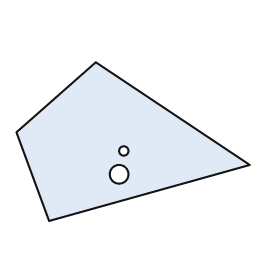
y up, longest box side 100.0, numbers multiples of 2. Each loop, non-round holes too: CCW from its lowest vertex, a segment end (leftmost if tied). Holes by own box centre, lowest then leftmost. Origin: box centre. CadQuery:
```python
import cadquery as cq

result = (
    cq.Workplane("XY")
    .moveTo(-36.0, -34.0)
    .lineTo(50.0, -10.0)
    .lineTo(-16.0, 34.0)
    .lineTo(-50.0, 4.0)
    .close()
    .moveTo(-6.0, -14.0)
    .circle(4.0)
    .moveTo(-4.0, -4.0)
    .circle(2.0)
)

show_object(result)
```